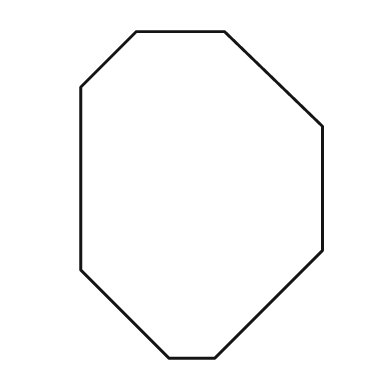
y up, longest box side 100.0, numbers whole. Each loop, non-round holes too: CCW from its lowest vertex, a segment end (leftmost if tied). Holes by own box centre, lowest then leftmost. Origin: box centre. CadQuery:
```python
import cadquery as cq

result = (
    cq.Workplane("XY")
    .moveTo(-10.0, -50.0)
    .lineTo(4.0, -50.0)
    .lineTo(37.0, -17.0)
    .lineTo(37.0, 21.0)
    .lineTo(7.0, 50.0)
    .lineTo(-20.0, 50.0)
    .lineTo(-37.0, 33.0)
    .lineTo(-37.0, -23.0)
    .close()
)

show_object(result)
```